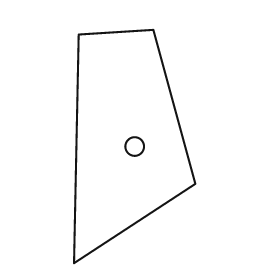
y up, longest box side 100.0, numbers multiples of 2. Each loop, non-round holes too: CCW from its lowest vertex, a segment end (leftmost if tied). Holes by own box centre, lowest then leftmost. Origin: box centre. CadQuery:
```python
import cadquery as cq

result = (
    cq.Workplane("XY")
    .moveTo(-26.0, -50.0)
    .lineTo(26.0, -16.0)
    .lineTo(8.0, 50.0)
    .lineTo(-24.0, 48.0)
    .close()
    .moveTo(0.0, 0.0)
    .circle(4.0)
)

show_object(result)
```